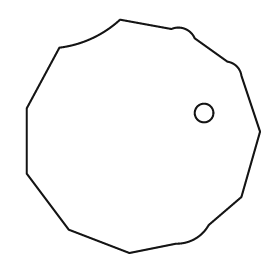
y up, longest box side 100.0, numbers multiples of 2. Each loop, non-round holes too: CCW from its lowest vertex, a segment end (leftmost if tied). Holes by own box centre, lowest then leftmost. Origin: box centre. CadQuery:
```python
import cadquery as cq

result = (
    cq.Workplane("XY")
    .moveTo(-6.0, -50.0)
    .lineTo(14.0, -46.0)
    .threePointArc((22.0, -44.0), (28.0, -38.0))
    .lineTo(42.0, -26.0)
    .lineTo(50.0, 2.0)
    .lineTo(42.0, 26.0)
    .threePointArc((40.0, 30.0), (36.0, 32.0))
    .lineTo(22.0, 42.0)
    .threePointArc((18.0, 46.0), (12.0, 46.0))
    .lineTo(-10.0, 50.0)
    .threePointArc((-22.0, 42.0), (-36.0, 38.0))
    .lineTo(-50.0, 12.0)
    .lineTo(-50.0, -16.0)
    .lineTo(-32.0, -40.0)
    .close()
    .moveTo(26.0, 10.0)
    .circle(4.0)
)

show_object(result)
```